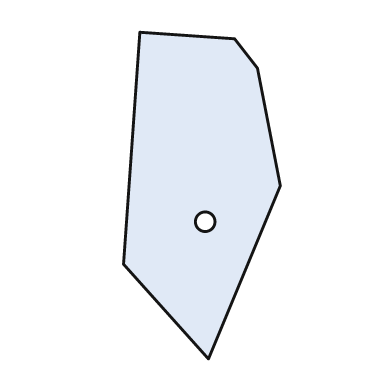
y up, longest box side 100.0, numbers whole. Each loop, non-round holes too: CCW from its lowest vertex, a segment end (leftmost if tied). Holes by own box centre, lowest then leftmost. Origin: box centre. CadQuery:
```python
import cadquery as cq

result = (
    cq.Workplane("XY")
    .moveTo(2.0, -50.0)
    .lineTo(24.0, 3.0)
    .lineTo(17.0, 39.0)
    .lineTo(10.0, 48.0)
    .lineTo(-19.0, 50.0)
    .lineTo(-24.0, -21.0)
    .close()
    .moveTo(1.0, -8.0)
    .circle(3.0)
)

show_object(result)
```